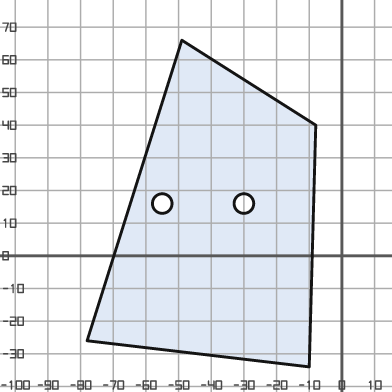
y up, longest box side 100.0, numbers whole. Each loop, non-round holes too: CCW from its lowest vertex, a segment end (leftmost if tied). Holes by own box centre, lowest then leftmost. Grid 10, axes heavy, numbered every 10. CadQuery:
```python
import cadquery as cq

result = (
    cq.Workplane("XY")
    .moveTo(-10.0, -34.0)
    .lineTo(-8.0, 40.0)
    .lineTo(-49.0, 66.0)
    .lineTo(-78.0, -26.0)
    .close()
    .moveTo(-55.0, 16.0)
    .circle(3.0)
    .moveTo(-30.0, 16.0)
    .circle(3.0)
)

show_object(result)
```